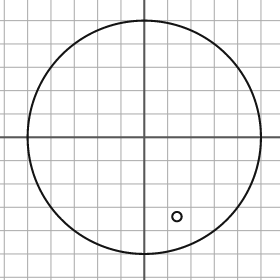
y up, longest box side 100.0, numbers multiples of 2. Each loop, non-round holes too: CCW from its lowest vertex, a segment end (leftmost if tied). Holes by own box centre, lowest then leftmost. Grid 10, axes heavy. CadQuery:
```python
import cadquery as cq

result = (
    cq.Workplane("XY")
    .moveTo(0.0, 0.0)
    .circle(50.0)
    .moveTo(14.0, -34.0)
    .circle(2.0)
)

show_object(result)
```